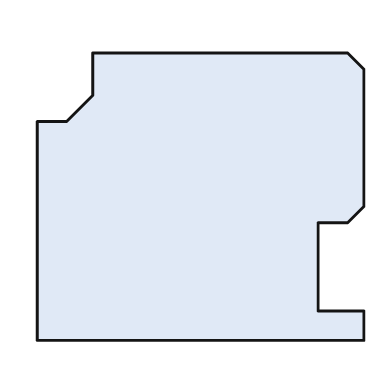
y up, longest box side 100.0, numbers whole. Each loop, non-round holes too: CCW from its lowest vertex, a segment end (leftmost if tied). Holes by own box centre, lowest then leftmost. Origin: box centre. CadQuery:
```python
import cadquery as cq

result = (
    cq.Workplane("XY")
    .moveTo(-50.0, -44.0)
    .lineTo(50.0, -44.0)
    .lineTo(50.0, -35.0)
    .lineTo(36.0, -35.0)
    .lineTo(36.0, -8.0)
    .lineTo(45.0, -8.0)
    .lineTo(50.0, -3.0)
    .lineTo(50.0, 39.0)
    .lineTo(45.0, 44.0)
    .lineTo(-33.0, 44.0)
    .lineTo(-33.0, 31.0)
    .lineTo(-41.0, 23.0)
    .lineTo(-50.0, 23.0)
    .close()
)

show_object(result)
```